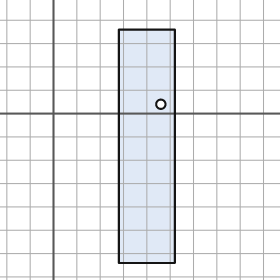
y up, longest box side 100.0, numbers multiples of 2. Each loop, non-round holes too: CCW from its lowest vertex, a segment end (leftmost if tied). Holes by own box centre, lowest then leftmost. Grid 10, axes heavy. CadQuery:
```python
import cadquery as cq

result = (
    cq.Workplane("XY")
    .moveTo(28.0, -64.0)
    .lineTo(52.0, -64.0)
    .lineTo(52.0, 36.0)
    .lineTo(28.0, 36.0)
    .close()
    .moveTo(46.0, 4.0)
    .circle(2.0)
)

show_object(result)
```